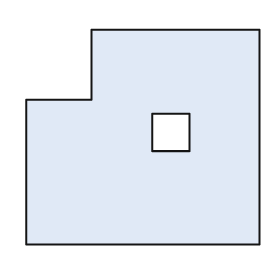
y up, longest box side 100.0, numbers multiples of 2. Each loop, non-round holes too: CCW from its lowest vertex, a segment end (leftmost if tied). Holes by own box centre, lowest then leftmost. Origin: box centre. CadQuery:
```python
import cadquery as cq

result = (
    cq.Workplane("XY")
    .moveTo(-50.0, -46.0)
    .lineTo(50.0, -46.0)
    .lineTo(50.0, 46.0)
    .lineTo(-22.0, 46.0)
    .lineTo(-22.0, 16.0)
    .lineTo(-50.0, 16.0)
    .close()
    .moveTo(4.0, -6.0)
    .lineTo(20.0, -6.0)
    .lineTo(20.0, 10.0)
    .lineTo(4.0, 10.0)
    .close()
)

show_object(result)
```